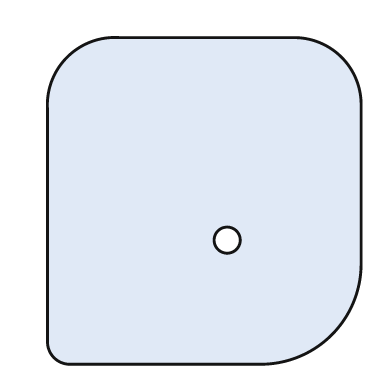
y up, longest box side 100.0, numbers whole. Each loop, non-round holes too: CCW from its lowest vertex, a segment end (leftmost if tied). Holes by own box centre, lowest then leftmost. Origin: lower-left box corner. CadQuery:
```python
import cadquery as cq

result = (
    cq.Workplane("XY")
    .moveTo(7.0, 0.0)
    .lineTo(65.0, 0.0)
    .threePointArc((87.0, 9.0), (96.0, 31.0))
    .lineTo(96.0, 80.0)
    .threePointArc((90.0, 94.0), (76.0, 100.0))
    .lineTo(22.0, 100.0)
    .threePointArc((6.0, 94.0), (0.0, 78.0))
    .lineTo(0.0, 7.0)
    .threePointArc((2.0, 2.0), (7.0, 0.0))
    .close()
    .moveTo(55.0, 38.0)
    .circle(4.0)
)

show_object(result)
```